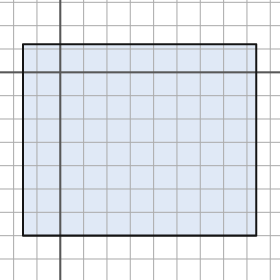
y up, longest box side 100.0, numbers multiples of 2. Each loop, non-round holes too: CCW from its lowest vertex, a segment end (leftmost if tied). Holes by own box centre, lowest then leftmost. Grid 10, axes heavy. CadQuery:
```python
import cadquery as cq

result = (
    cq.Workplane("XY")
    .moveTo(-16.0, -70.0)
    .lineTo(84.0, -70.0)
    .lineTo(84.0, 12.0)
    .lineTo(-16.0, 12.0)
    .close()
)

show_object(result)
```